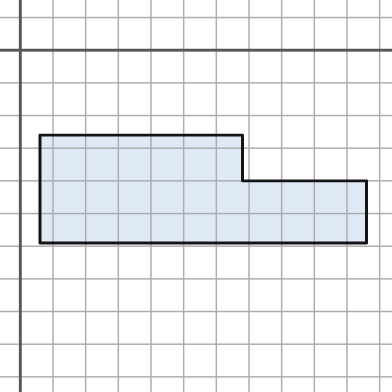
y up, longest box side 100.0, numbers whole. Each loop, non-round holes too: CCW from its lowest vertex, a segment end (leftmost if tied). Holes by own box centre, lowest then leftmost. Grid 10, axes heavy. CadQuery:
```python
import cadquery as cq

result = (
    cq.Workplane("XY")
    .moveTo(6.0, -59.0)
    .lineTo(106.0, -59.0)
    .lineTo(106.0, -40.0)
    .lineTo(68.0, -40.0)
    .lineTo(68.0, -26.0)
    .lineTo(6.0, -26.0)
    .close()
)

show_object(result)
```